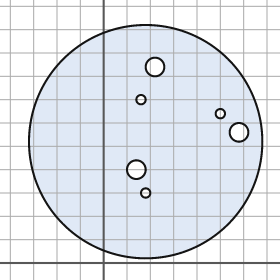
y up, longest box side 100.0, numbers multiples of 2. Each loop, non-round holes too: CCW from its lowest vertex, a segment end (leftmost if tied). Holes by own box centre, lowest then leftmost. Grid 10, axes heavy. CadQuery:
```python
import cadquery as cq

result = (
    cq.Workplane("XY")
    .moveTo(18.0, 52.0)
    .circle(50.0)
    .moveTo(18.0, 30.0)
    .circle(2.0)
    .moveTo(14.0, 40.0)
    .circle(4.0)
    .moveTo(58.0, 56.0)
    .circle(4.0)
    .moveTo(50.0, 64.0)
    .circle(2.0)
    .moveTo(16.0, 70.0)
    .circle(2.0)
    .moveTo(22.0, 84.0)
    .circle(4.0)
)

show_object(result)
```